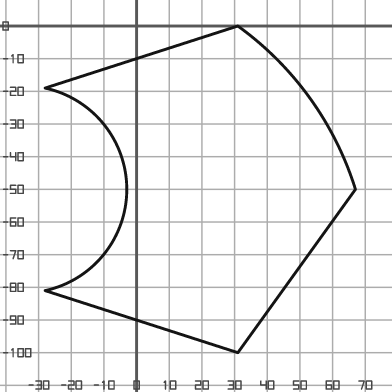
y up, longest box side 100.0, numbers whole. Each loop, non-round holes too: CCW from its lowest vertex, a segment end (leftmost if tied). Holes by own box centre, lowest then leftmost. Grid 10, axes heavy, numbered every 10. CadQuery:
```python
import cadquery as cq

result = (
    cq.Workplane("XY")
    .moveTo(31.0, -100.0)
    .lineTo(67.0, -50.0)
    .threePointArc((53.0, -22.0), (31.0, 0.0))
    .lineTo(-28.0, -19.0)
    .threePointArc((-3.0, -50.0), (-28.0, -81.0))
    .close()
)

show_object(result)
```